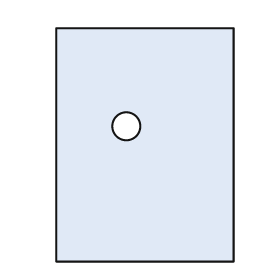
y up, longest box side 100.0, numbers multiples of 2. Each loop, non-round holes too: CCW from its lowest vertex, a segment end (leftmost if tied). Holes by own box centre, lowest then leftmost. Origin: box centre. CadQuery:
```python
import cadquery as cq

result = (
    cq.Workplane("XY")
    .moveTo(-38.0, -50.0)
    .lineTo(38.0, -50.0)
    .lineTo(38.0, 50.0)
    .lineTo(-38.0, 50.0)
    .close()
    .moveTo(-8.0, 8.0)
    .circle(6.0)
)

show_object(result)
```